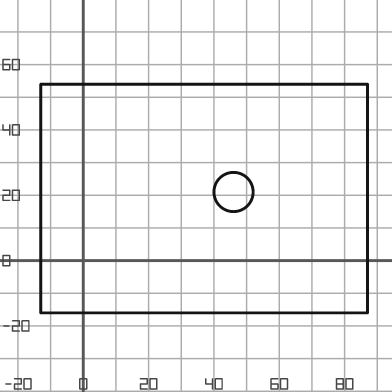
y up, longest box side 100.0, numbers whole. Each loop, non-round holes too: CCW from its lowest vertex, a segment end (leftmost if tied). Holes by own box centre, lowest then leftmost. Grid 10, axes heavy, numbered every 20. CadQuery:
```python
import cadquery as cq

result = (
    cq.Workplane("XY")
    .moveTo(-13.0, -16.0)
    .lineTo(87.0, -16.0)
    .lineTo(87.0, 54.0)
    .lineTo(-13.0, 54.0)
    .close()
    .moveTo(46.0, 21.0)
    .circle(6.0)
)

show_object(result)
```